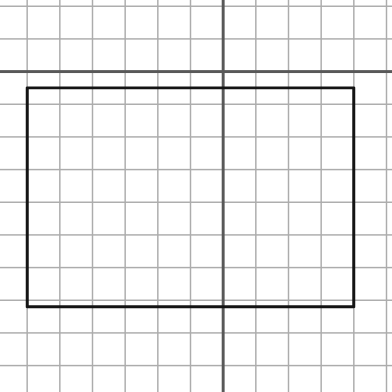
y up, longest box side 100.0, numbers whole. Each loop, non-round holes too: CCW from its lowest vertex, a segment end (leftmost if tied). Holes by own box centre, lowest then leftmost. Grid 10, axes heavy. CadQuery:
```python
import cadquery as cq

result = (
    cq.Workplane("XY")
    .moveTo(-60.0, -72.0)
    .lineTo(40.0, -72.0)
    .lineTo(40.0, -5.0)
    .lineTo(-60.0, -5.0)
    .close()
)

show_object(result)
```